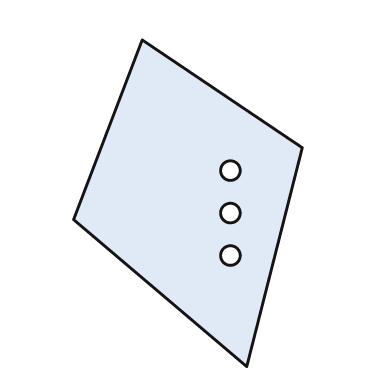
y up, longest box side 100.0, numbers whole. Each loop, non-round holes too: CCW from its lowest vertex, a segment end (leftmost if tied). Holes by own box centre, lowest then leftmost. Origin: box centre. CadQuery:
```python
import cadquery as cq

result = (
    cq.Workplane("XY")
    .moveTo(18.0, -50.0)
    .lineTo(35.0, 17.0)
    .lineTo(-14.0, 50.0)
    .lineTo(-35.0, -5.0)
    .close()
    .moveTo(13.0, -16.0)
    .circle(3.0)
    .moveTo(13.0, -3.0)
    .circle(3.0)
    .moveTo(13.0, 10.0)
    .circle(3.0)
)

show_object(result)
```